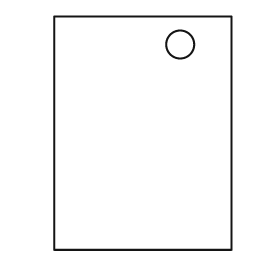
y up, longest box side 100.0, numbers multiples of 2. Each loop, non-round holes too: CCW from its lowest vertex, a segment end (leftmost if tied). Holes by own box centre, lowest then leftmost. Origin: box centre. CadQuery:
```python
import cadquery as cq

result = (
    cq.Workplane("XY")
    .moveTo(-38.0, -50.0)
    .lineTo(38.0, -50.0)
    .lineTo(38.0, 50.0)
    .lineTo(-38.0, 50.0)
    .close()
    .moveTo(16.0, 38.0)
    .circle(6.0)
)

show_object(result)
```